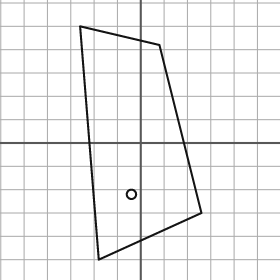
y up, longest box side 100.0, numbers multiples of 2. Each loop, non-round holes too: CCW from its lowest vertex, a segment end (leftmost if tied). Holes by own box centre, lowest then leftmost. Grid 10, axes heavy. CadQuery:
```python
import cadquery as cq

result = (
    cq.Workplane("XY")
    .moveTo(-18.0, -50.0)
    .lineTo(26.0, -30.0)
    .lineTo(8.0, 42.0)
    .lineTo(-26.0, 50.0)
    .close()
    .moveTo(-4.0, -22.0)
    .circle(2.0)
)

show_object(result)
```